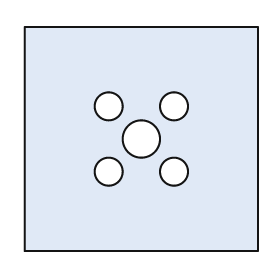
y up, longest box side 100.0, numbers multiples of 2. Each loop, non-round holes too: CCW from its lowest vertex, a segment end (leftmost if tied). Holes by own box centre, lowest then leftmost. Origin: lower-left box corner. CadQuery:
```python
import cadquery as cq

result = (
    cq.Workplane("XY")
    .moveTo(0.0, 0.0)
    .lineTo(100.0, 0.0)
    .lineTo(100.0, 96.0)
    .lineTo(0.0, 96.0)
    .close()
    .moveTo(36.0, 34.0)
    .circle(6.0)
    .moveTo(64.0, 34.0)
    .circle(6.0)
    .moveTo(50.0, 48.0)
    .circle(8.0)
    .moveTo(36.0, 62.0)
    .circle(6.0)
    .moveTo(64.0, 62.0)
    .circle(6.0)
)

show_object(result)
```